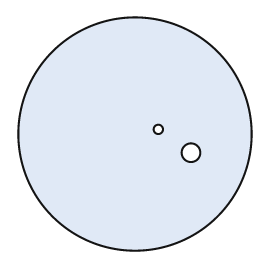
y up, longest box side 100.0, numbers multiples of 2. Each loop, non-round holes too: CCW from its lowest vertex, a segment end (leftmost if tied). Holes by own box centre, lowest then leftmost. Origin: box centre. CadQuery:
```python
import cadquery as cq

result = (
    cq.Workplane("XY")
    .moveTo(0.0, 0.0)
    .circle(50.0)
    .moveTo(24.0, -8.0)
    .circle(4.0)
    .moveTo(10.0, 2.0)
    .circle(2.0)
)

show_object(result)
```